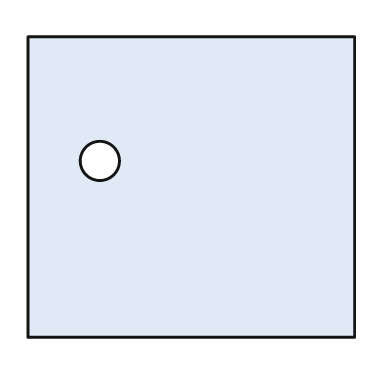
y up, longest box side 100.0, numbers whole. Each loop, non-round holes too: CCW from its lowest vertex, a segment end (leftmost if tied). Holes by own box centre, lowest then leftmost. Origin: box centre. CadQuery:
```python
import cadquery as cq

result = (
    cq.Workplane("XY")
    .moveTo(-50.0, -46.0)
    .lineTo(50.0, -46.0)
    .lineTo(50.0, 46.0)
    .lineTo(-50.0, 46.0)
    .close()
    .moveTo(-28.0, 8.0)
    .circle(6.0)
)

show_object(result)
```